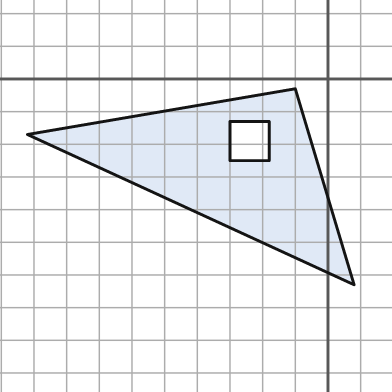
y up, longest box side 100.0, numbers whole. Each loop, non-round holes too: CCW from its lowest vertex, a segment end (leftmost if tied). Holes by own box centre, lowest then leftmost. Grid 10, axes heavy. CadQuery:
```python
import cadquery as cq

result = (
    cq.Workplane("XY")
    .moveTo(8.0, -63.0)
    .lineTo(-10.0, -3.0)
    .lineTo(-92.0, -17.0)
    .close()
    .moveTo(-30.0, -25.0)
    .lineTo(-18.0, -25.0)
    .lineTo(-18.0, -13.0)
    .lineTo(-30.0, -13.0)
    .close()
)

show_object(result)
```